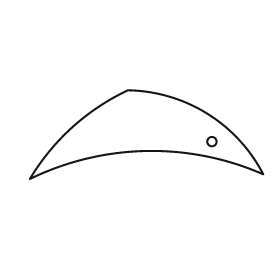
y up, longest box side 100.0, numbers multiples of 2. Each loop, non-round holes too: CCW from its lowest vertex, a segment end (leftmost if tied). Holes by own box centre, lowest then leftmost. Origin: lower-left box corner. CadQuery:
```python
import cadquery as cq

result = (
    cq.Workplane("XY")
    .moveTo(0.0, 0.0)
    .threePointArc((50.0, 12.0), (100.0, 2.0))
    .threePointArc((76.0, 28.0), (42.0, 38.0))
    .threePointArc((18.0, 22.0), (0.0, 0.0))
    .close()
    .moveTo(78.0, 16.0)
    .circle(2.0)
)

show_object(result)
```